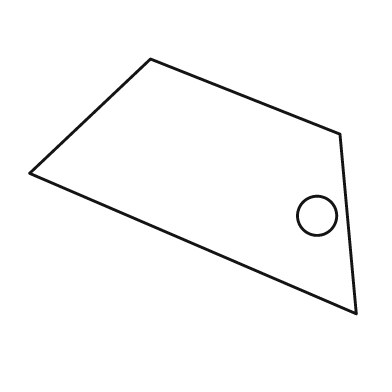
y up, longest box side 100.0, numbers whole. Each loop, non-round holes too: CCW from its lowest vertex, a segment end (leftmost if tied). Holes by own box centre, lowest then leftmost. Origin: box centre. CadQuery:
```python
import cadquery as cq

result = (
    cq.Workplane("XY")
    .moveTo(50.0, -39.0)
    .lineTo(45.0, 16.0)
    .lineTo(-13.0, 39.0)
    .lineTo(-50.0, 4.0)
    .close()
    .moveTo(38.0, -9.0)
    .circle(6.0)
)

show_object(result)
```